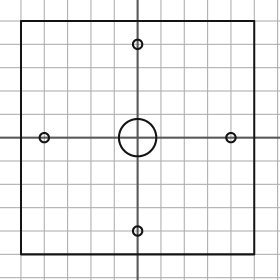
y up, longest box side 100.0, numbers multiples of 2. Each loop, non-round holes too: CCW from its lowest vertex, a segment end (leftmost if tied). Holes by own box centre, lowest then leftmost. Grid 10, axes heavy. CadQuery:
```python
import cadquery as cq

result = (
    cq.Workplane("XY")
    .moveTo(-50.0, -50.0)
    .lineTo(50.0, -50.0)
    .lineTo(50.0, 50.0)
    .lineTo(-50.0, 50.0)
    .close()
    .moveTo(0.0, -40.0)
    .circle(2.0)
    .moveTo(-40.0, 0.0)
    .circle(2.0)
    .moveTo(0.0, 0.0)
    .circle(8.0)
    .moveTo(40.0, 0.0)
    .circle(2.0)
    .moveTo(0.0, 40.0)
    .circle(2.0)
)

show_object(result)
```